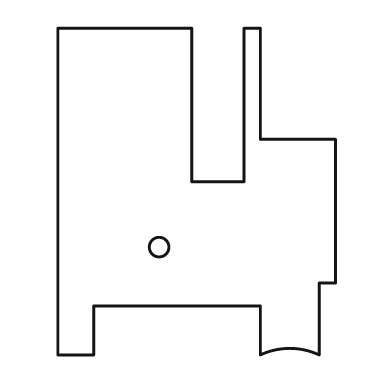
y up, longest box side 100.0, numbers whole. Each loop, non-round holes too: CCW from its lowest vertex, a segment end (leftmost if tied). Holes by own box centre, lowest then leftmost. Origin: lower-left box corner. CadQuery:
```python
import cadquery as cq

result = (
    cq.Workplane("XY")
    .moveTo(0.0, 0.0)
    .lineTo(11.0, 0.0)
    .lineTo(11.0, 15.0)
    .lineTo(62.0, 15.0)
    .lineTo(62.0, 0.0)
    .threePointArc((71.0, 2.0), (80.0, 0.0))
    .lineTo(80.0, 22.0)
    .lineTo(85.0, 22.0)
    .lineTo(85.0, 66.0)
    .lineTo(62.0, 66.0)
    .lineTo(62.0, 100.0)
    .lineTo(57.0, 100.0)
    .lineTo(57.0, 53.0)
    .lineTo(41.0, 53.0)
    .lineTo(41.0, 100.0)
    .lineTo(0.0, 100.0)
    .close()
    .moveTo(31.0, 33.0)
    .circle(3.0)
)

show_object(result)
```